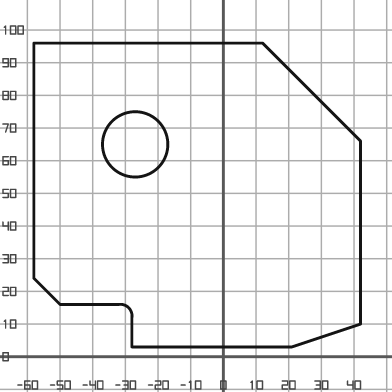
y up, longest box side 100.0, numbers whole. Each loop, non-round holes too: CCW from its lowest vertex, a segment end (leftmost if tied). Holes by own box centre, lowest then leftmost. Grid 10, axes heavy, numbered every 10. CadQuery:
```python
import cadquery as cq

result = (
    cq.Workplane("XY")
    .moveTo(-28.0, 3.0)
    .lineTo(21.0, 3.0)
    .lineTo(42.0, 10.0)
    .lineTo(42.0, 66.0)
    .lineTo(12.0, 96.0)
    .lineTo(-58.0, 96.0)
    .lineTo(-58.0, 24.0)
    .lineTo(-50.0, 16.0)
    .lineTo(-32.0, 16.0)
    .threePointArc((-29.0, 15.0), (-28.0, 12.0))
    .close()
    .moveTo(-27.0, 65.0)
    .circle(10.0)
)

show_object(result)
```